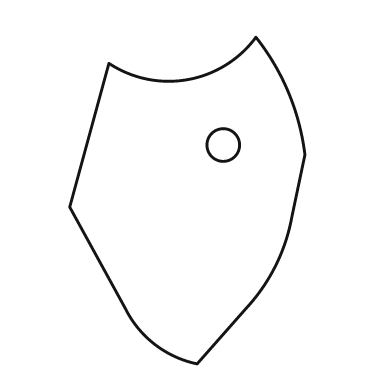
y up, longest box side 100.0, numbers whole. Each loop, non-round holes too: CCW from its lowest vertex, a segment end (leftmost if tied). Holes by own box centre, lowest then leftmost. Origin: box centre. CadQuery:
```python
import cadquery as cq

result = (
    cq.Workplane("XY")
    .moveTo(3.0, -50.0)
    .lineTo(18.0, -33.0)
    .threePointArc((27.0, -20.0), (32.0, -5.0))
    .lineTo(36.0, 14.0)
    .threePointArc((31.0, 33.0), (21.0, 50.0))
    .threePointArc((0.0, 37.0), (-24.0, 42.0))
    .lineTo(-36.0, -2.0)
    .lineTo(-19.0, -33.0)
    .threePointArc((-10.0, -44.0), (3.0, -50.0))
    .close()
    .moveTo(11.0, 17.0)
    .circle(5.0)
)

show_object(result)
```